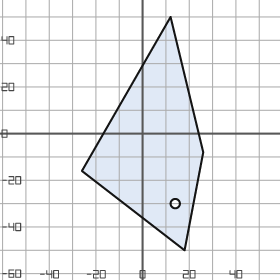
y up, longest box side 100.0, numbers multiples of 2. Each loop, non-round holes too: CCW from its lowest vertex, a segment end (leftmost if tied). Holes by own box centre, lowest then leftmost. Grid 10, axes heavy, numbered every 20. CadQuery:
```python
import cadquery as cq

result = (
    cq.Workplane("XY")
    .moveTo(18.0, -50.0)
    .lineTo(26.0, -8.0)
    .lineTo(12.0, 50.0)
    .lineTo(-26.0, -16.0)
    .close()
    .moveTo(14.0, -30.0)
    .circle(2.0)
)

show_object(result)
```